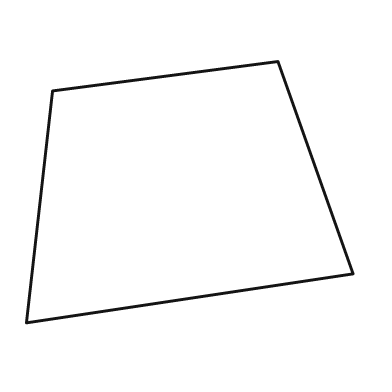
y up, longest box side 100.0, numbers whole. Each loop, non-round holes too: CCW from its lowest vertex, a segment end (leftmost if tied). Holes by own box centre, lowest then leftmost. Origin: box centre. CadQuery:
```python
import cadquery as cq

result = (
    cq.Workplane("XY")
    .moveTo(-50.0, -40.0)
    .lineTo(50.0, -25.0)
    .lineTo(27.0, 40.0)
    .lineTo(-42.0, 31.0)
    .close()
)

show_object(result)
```